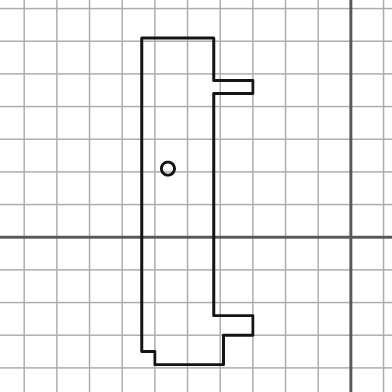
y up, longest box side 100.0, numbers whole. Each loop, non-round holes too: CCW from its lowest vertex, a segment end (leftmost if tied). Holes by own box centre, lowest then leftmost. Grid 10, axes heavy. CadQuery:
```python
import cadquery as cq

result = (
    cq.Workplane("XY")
    .moveTo(-60.0, -39.0)
    .lineTo(-39.0, -39.0)
    .lineTo(-39.0, -30.0)
    .lineTo(-30.0, -30.0)
    .lineTo(-30.0, -24.0)
    .lineTo(-42.0, -24.0)
    .lineTo(-42.0, 44.0)
    .lineTo(-30.0, 44.0)
    .lineTo(-30.0, 48.0)
    .lineTo(-42.0, 48.0)
    .lineTo(-42.0, 61.0)
    .lineTo(-64.0, 61.0)
    .lineTo(-64.0, -35.0)
    .lineTo(-60.0, -35.0)
    .close()
    .moveTo(-56.0, 21.0)
    .circle(2.0)
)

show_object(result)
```